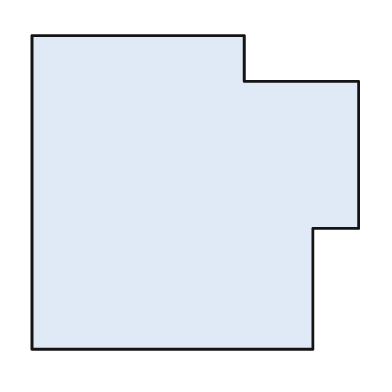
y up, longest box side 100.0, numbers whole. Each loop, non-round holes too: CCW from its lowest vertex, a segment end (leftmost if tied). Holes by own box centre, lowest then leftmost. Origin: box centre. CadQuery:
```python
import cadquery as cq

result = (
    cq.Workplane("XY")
    .moveTo(-50.0, -48.0)
    .lineTo(36.0, -48.0)
    .lineTo(36.0, -11.0)
    .lineTo(50.0, -11.0)
    .lineTo(50.0, 34.0)
    .lineTo(15.0, 34.0)
    .lineTo(15.0, 48.0)
    .lineTo(-50.0, 48.0)
    .close()
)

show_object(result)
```